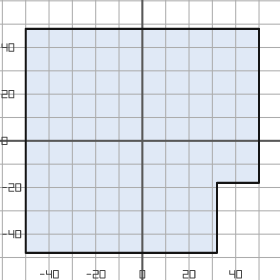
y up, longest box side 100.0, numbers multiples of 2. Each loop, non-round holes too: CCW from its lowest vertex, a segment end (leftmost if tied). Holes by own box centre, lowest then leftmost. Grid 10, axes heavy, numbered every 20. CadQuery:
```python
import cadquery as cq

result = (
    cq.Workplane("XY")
    .moveTo(-50.0, -48.0)
    .lineTo(32.0, -48.0)
    .lineTo(32.0, -18.0)
    .lineTo(50.0, -18.0)
    .lineTo(50.0, 48.0)
    .lineTo(-50.0, 48.0)
    .close()
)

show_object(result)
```